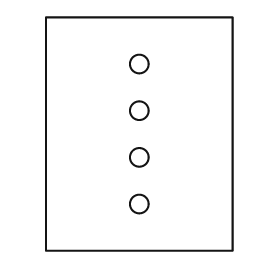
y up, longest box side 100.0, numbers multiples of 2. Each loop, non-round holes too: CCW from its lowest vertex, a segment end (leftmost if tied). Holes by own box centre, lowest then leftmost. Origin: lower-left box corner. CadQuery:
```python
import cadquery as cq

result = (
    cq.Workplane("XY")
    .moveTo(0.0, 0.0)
    .lineTo(80.0, 0.0)
    .lineTo(80.0, 100.0)
    .lineTo(0.0, 100.0)
    .close()
    .moveTo(40.0, 20.0)
    .circle(4.0)
    .moveTo(40.0, 40.0)
    .circle(4.0)
    .moveTo(40.0, 60.0)
    .circle(4.0)
    .moveTo(40.0, 80.0)
    .circle(4.0)
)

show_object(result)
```